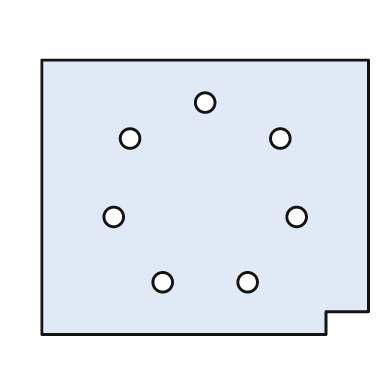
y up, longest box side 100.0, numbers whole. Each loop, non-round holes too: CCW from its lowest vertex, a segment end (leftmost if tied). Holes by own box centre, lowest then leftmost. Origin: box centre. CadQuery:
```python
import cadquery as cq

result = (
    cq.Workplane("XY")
    .moveTo(-50.0, -42.0)
    .lineTo(37.0, -42.0)
    .lineTo(37.0, -35.0)
    .lineTo(50.0, -35.0)
    .lineTo(50.0, 42.0)
    .lineTo(-50.0, 42.0)
    .close()
    .moveTo(-13.0, -26.0)
    .circle(3.0)
    .moveTo(13.0, -26.0)
    .circle(3.0)
    .moveTo(-28.0, -6.0)
    .circle(3.0)
    .moveTo(28.0, -6.0)
    .circle(3.0)
    .moveTo(-23.0, 18.0)
    .circle(3.0)
    .moveTo(23.0, 18.0)
    .circle(3.0)
    .moveTo(0.0, 29.0)
    .circle(3.0)
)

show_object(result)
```